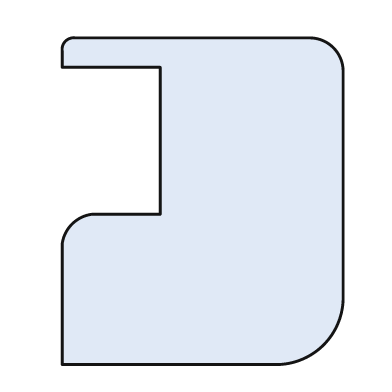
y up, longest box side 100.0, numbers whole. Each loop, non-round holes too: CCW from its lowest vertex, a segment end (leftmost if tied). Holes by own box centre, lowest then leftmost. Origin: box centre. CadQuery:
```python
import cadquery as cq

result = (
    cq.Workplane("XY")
    .moveTo(-43.0, -50.0)
    .lineTo(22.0, -50.0)
    .threePointArc((37.0, -44.0), (43.0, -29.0))
    .lineTo(43.0, 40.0)
    .threePointArc((40.0, 47.0), (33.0, 50.0))
    .lineTo(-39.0, 50.0)
    .threePointArc((-42.0, 49.0), (-43.0, 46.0))
    .lineTo(-43.0, 41.0)
    .lineTo(-13.0, 41.0)
    .lineTo(-13.0, -4.0)
    .lineTo(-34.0, -4.0)
    .threePointArc((-40.0, -7.0), (-43.0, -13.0))
    .close()
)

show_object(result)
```